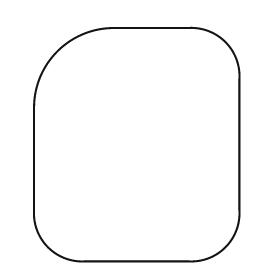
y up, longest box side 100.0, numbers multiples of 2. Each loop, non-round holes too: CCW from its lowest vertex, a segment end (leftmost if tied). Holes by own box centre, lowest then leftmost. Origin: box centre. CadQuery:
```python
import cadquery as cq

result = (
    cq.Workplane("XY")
    .moveTo(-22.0, -50.0)
    .lineTo(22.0, -50.0)
    .threePointArc((38.0, -44.0), (44.0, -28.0))
    .lineTo(44.0, 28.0)
    .threePointArc((38.0, 44.0), (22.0, 50.0))
    .lineTo(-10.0, 50.0)
    .threePointArc((-34.0, 40.0), (-44.0, 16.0))
    .lineTo(-44.0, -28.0)
    .threePointArc((-38.0, -44.0), (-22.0, -50.0))
    .close()
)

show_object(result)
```